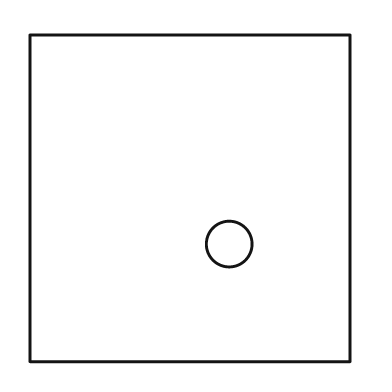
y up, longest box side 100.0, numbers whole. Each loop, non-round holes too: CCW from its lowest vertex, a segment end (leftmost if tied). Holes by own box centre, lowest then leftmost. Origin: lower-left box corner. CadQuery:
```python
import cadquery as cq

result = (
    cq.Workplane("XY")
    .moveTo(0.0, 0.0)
    .lineTo(98.0, 0.0)
    .lineTo(98.0, 100.0)
    .lineTo(0.0, 100.0)
    .close()
    .moveTo(61.0, 36.0)
    .circle(7.0)
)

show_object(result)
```